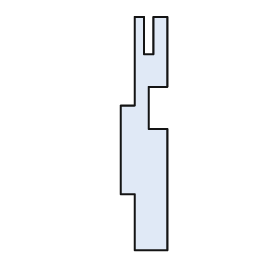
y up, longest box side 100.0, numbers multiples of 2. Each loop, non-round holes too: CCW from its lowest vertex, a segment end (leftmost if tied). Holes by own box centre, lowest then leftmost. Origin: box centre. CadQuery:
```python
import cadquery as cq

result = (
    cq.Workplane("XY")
    .moveTo(-4.0, -50.0)
    .lineTo(10.0, -50.0)
    .lineTo(10.0, 2.0)
    .lineTo(2.0, 2.0)
    .lineTo(2.0, 20.0)
    .lineTo(10.0, 20.0)
    .lineTo(10.0, 50.0)
    .lineTo(4.0, 50.0)
    .lineTo(4.0, 34.0)
    .lineTo(0.0, 34.0)
    .lineTo(0.0, 50.0)
    .lineTo(-4.0, 50.0)
    .lineTo(-4.0, 12.0)
    .lineTo(-10.0, 12.0)
    .lineTo(-10.0, -26.0)
    .lineTo(-4.0, -26.0)
    .close()
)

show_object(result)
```